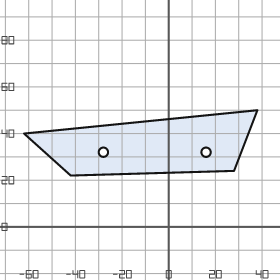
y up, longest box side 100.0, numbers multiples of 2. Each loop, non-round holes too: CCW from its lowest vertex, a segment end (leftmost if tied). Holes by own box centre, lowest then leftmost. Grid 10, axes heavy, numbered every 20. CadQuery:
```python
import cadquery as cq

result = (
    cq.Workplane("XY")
    .moveTo(-42.0, 22.0)
    .lineTo(28.0, 24.0)
    .lineTo(38.0, 50.0)
    .lineTo(-62.0, 40.0)
    .close()
    .moveTo(-28.0, 32.0)
    .circle(2.0)
    .moveTo(16.0, 32.0)
    .circle(2.0)
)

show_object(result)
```